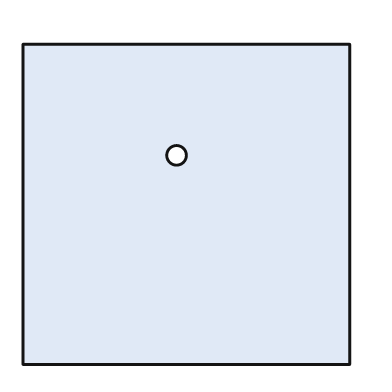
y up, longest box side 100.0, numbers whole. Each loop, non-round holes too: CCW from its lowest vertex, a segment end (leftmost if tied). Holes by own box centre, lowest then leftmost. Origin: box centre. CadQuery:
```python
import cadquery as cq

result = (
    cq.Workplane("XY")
    .moveTo(-50.0, -49.0)
    .lineTo(50.0, -49.0)
    .lineTo(50.0, 49.0)
    .lineTo(-50.0, 49.0)
    .close()
    .moveTo(-3.0, 15.0)
    .circle(3.0)
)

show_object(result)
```